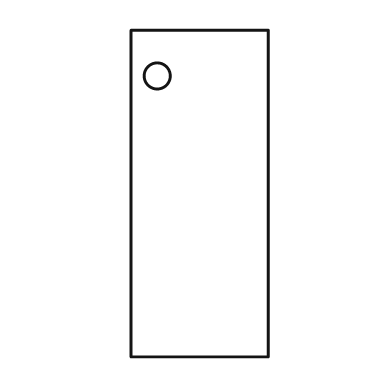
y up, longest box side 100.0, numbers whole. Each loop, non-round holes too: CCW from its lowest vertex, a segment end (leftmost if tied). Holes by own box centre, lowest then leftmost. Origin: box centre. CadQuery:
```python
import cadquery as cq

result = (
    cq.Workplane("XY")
    .moveTo(-21.0, -50.0)
    .lineTo(21.0, -50.0)
    .lineTo(21.0, 50.0)
    .lineTo(-21.0, 50.0)
    .close()
    .moveTo(-13.0, 36.0)
    .circle(4.0)
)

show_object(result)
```